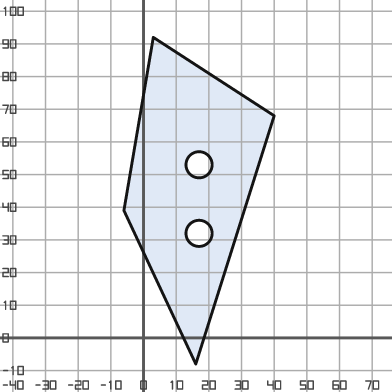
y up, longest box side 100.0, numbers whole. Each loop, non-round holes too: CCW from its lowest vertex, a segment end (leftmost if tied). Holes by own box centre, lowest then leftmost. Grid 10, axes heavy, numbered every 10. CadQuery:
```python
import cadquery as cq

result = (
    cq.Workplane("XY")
    .moveTo(16.0, -8.0)
    .lineTo(40.0, 68.0)
    .lineTo(3.0, 92.0)
    .lineTo(-6.0, 39.0)
    .close()
    .moveTo(17.0, 32.0)
    .circle(4.0)
    .moveTo(17.0, 53.0)
    .circle(4.0)
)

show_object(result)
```